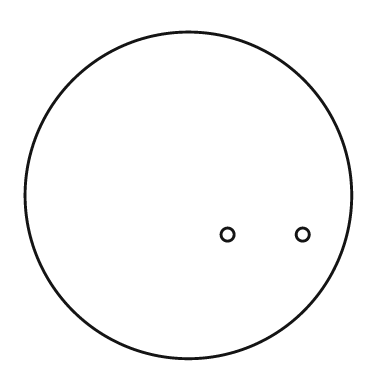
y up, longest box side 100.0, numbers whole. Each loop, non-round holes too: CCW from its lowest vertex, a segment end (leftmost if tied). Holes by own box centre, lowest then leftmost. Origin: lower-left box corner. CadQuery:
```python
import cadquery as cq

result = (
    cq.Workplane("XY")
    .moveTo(50.0, 50.0)
    .circle(50.0)
    .moveTo(62.0, 38.0)
    .circle(2.0)
    .moveTo(85.0, 38.0)
    .circle(2.0)
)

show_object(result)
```